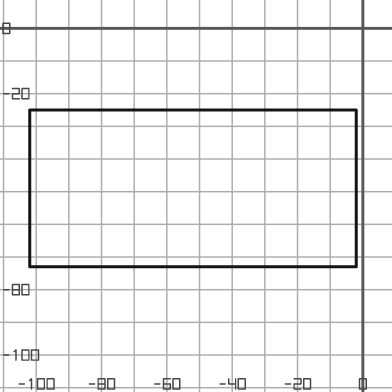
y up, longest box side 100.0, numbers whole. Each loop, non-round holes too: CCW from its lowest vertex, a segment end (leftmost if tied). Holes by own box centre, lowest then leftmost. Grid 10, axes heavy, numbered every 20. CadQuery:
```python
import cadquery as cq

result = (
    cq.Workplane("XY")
    .moveTo(-102.0, -73.0)
    .lineTo(-2.0, -73.0)
    .lineTo(-2.0, -25.0)
    .lineTo(-102.0, -25.0)
    .close()
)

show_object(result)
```